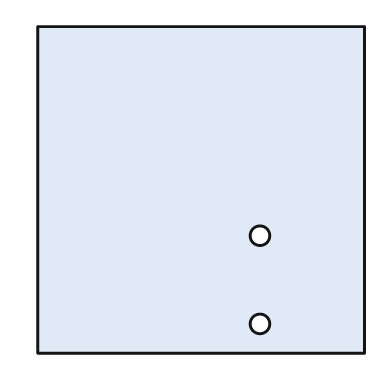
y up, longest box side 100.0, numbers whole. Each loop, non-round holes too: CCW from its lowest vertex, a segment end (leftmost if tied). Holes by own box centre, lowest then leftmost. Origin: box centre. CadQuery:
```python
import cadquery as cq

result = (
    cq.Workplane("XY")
    .moveTo(-50.0, -50.0)
    .lineTo(50.0, -50.0)
    .lineTo(50.0, 50.0)
    .lineTo(-50.0, 50.0)
    .close()
    .moveTo(18.0, -41.0)
    .circle(3.0)
    .moveTo(18.0, -14.0)
    .circle(3.0)
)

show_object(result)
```